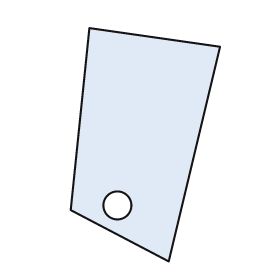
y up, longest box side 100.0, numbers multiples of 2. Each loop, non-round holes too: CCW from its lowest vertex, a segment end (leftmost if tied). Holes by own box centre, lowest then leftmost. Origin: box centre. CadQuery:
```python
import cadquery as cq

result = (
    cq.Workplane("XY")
    .moveTo(10.0, -50.0)
    .lineTo(32.0, 42.0)
    .lineTo(-24.0, 50.0)
    .lineTo(-32.0, -28.0)
    .close()
    .moveTo(-12.0, -26.0)
    .circle(6.0)
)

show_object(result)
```